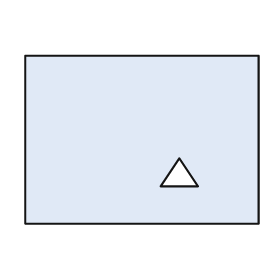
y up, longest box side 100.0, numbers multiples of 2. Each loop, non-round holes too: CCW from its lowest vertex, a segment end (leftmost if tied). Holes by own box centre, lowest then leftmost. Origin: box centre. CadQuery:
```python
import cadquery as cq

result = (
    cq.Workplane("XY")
    .moveTo(-50.0, -36.0)
    .lineTo(50.0, -36.0)
    .lineTo(50.0, 36.0)
    .lineTo(-50.0, 36.0)
    .close()
    .moveTo(8.0, -20.0)
    .lineTo(24.0, -20.0)
    .lineTo(16.0, -8.0)
    .close()
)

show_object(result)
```